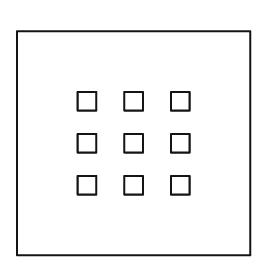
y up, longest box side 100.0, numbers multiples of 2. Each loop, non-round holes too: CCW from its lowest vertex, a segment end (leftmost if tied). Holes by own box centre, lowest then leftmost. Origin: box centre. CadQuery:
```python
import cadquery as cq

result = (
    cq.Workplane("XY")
    .moveTo(-50.0, -48.0)
    .lineTo(50.0, -48.0)
    .lineTo(50.0, 48.0)
    .lineTo(-50.0, 48.0)
    .close()
    .moveTo(-24.0, -22.0)
    .lineTo(-16.0, -22.0)
    .lineTo(-16.0, -14.0)
    .lineTo(-24.0, -14.0)
    .close()
    .moveTo(-4.0, -22.0)
    .lineTo(4.0, -22.0)
    .lineTo(4.0, -14.0)
    .lineTo(-4.0, -14.0)
    .close()
    .moveTo(16.0, -22.0)
    .lineTo(24.0, -22.0)
    .lineTo(24.0, -14.0)
    .lineTo(16.0, -14.0)
    .close()
    .moveTo(-24.0, -4.0)
    .lineTo(-16.0, -4.0)
    .lineTo(-16.0, 4.0)
    .lineTo(-24.0, 4.0)
    .close()
    .moveTo(-4.0, -4.0)
    .lineTo(4.0, -4.0)
    .lineTo(4.0, 4.0)
    .lineTo(-4.0, 4.0)
    .close()
    .moveTo(16.0, -4.0)
    .lineTo(24.0, -4.0)
    .lineTo(24.0, 4.0)
    .lineTo(16.0, 4.0)
    .close()
    .moveTo(-24.0, 14.0)
    .lineTo(-16.0, 14.0)
    .lineTo(-16.0, 22.0)
    .lineTo(-24.0, 22.0)
    .close()
    .moveTo(-4.0, 14.0)
    .lineTo(4.0, 14.0)
    .lineTo(4.0, 22.0)
    .lineTo(-4.0, 22.0)
    .close()
    .moveTo(16.0, 14.0)
    .lineTo(24.0, 14.0)
    .lineTo(24.0, 22.0)
    .lineTo(16.0, 22.0)
    .close()
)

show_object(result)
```